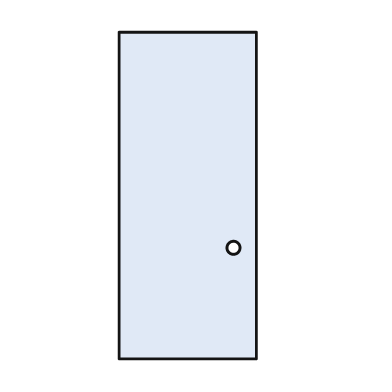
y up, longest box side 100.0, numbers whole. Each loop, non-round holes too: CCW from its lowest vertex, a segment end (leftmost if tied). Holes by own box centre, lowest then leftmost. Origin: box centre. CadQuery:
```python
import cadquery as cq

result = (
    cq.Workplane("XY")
    .moveTo(-21.0, -50.0)
    .lineTo(21.0, -50.0)
    .lineTo(21.0, 50.0)
    .lineTo(-21.0, 50.0)
    .close()
    .moveTo(14.0, -16.0)
    .circle(2.0)
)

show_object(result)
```